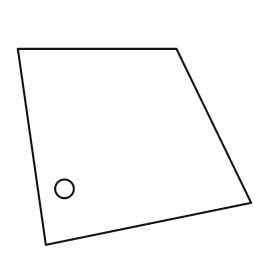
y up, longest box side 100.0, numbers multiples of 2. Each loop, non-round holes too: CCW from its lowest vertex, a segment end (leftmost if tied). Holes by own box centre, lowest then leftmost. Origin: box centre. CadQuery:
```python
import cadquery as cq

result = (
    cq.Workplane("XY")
    .moveTo(-38.0, -42.0)
    .lineTo(50.0, -24.0)
    .lineTo(18.0, 42.0)
    .lineTo(-50.0, 42.0)
    .close()
    .moveTo(-30.0, -18.0)
    .circle(4.0)
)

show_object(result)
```